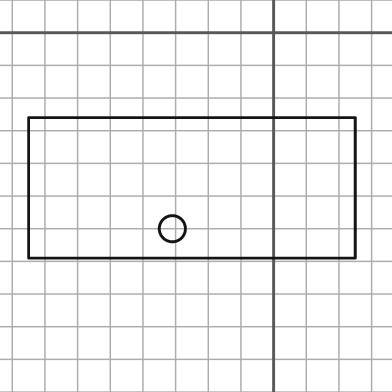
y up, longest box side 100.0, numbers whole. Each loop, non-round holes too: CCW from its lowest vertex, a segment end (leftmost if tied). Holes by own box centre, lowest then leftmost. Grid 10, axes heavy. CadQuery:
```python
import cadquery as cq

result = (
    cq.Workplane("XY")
    .moveTo(-75.0, -69.0)
    .lineTo(25.0, -69.0)
    .lineTo(25.0, -26.0)
    .lineTo(-75.0, -26.0)
    .close()
    .moveTo(-31.0, -60.0)
    .circle(4.0)
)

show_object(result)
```